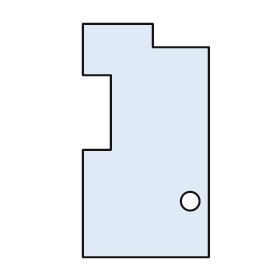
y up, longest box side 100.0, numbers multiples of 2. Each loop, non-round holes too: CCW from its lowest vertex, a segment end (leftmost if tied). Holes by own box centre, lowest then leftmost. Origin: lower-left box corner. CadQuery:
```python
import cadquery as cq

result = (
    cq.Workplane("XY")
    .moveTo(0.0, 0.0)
    .lineTo(54.0, 0.0)
    .lineTo(54.0, 90.0)
    .lineTo(30.0, 90.0)
    .lineTo(30.0, 100.0)
    .lineTo(0.0, 100.0)
    .lineTo(0.0, 78.0)
    .lineTo(12.0, 78.0)
    .lineTo(12.0, 46.0)
    .lineTo(0.0, 46.0)
    .close()
    .moveTo(46.0, 24.0)
    .circle(4.0)
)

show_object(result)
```